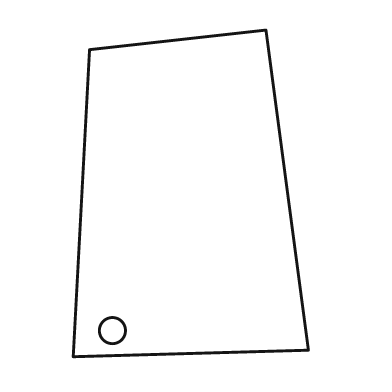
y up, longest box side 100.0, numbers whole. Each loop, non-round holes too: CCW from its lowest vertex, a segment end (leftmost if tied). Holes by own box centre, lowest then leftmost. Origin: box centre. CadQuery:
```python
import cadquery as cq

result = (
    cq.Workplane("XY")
    .moveTo(-36.0, -50.0)
    .lineTo(36.0, -48.0)
    .lineTo(23.0, 50.0)
    .lineTo(-31.0, 44.0)
    .close()
    .moveTo(-24.0, -42.0)
    .circle(4.0)
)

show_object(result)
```